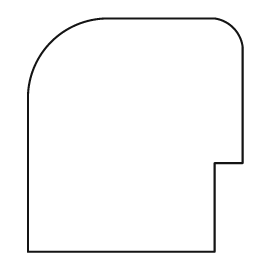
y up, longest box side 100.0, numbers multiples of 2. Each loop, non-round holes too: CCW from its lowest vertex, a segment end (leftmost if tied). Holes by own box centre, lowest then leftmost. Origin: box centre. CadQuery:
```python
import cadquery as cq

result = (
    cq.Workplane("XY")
    .moveTo(-46.0, -50.0)
    .lineTo(34.0, -50.0)
    .lineTo(34.0, -12.0)
    .lineTo(46.0, -12.0)
    .lineTo(46.0, 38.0)
    .threePointArc((42.0, 46.0), (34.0, 50.0))
    .lineTo(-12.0, 50.0)
    .threePointArc((-36.0, 40.0), (-46.0, 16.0))
    .close()
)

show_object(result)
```